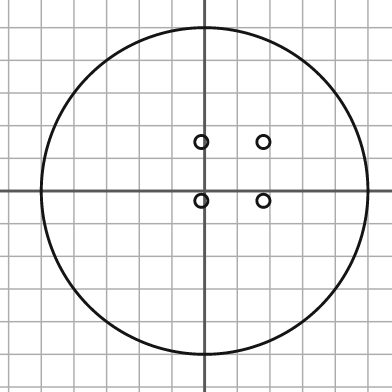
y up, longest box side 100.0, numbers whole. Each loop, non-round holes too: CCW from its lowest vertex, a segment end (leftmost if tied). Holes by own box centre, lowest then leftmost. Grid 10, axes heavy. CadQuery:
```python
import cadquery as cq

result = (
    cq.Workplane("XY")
    .moveTo(0.0, 0.0)
    .circle(50.0)
    .moveTo(-1.0, -3.0)
    .circle(2.0)
    .moveTo(18.0, -3.0)
    .circle(2.0)
    .moveTo(-1.0, 15.0)
    .circle(2.0)
    .moveTo(18.0, 15.0)
    .circle(2.0)
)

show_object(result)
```